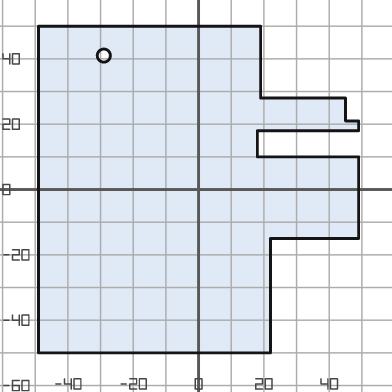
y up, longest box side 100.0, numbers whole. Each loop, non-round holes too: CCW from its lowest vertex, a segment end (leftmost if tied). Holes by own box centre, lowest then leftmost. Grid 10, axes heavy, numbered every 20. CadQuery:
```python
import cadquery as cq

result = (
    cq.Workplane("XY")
    .moveTo(-49.0, -50.0)
    .lineTo(22.0, -50.0)
    .lineTo(22.0, -15.0)
    .lineTo(49.0, -15.0)
    .lineTo(49.0, 10.0)
    .lineTo(18.0, 10.0)
    .lineTo(18.0, 18.0)
    .lineTo(49.0, 18.0)
    .lineTo(49.0, 21.0)
    .lineTo(45.0, 21.0)
    .lineTo(45.0, 28.0)
    .lineTo(19.0, 28.0)
    .lineTo(19.0, 50.0)
    .lineTo(-49.0, 50.0)
    .close()
    .moveTo(-29.0, 41.0)
    .circle(2.0)
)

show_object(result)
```